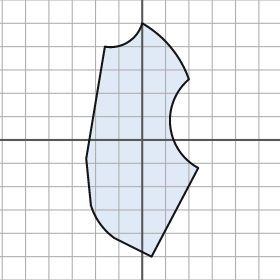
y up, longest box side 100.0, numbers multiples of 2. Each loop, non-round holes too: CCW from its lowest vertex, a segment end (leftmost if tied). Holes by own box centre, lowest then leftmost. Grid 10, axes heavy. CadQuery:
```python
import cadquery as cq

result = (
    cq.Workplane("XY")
    .moveTo(4.0, -50.0)
    .lineTo(24.0, -12.0)
    .threePointArc((12.0, 6.0), (20.0, 26.0))
    .threePointArc((12.0, 40.0), (0.0, 50.0))
    .threePointArc((-6.0, 42.0), (-16.0, 40.0))
    .lineTo(-24.0, -8.0)
    .lineTo(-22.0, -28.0)
    .threePointArc((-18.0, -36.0), (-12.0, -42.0))
    .close()
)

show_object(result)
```